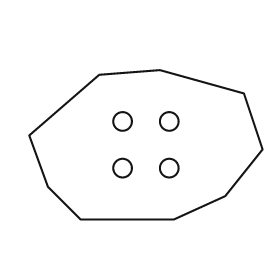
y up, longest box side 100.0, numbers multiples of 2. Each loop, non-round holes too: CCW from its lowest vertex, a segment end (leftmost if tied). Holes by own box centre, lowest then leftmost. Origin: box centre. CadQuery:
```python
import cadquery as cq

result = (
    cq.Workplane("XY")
    .moveTo(-28.0, -32.0)
    .lineTo(12.0, -32.0)
    .lineTo(34.0, -22.0)
    .lineTo(50.0, -2.0)
    .lineTo(42.0, 22.0)
    .lineTo(6.0, 32.0)
    .lineTo(-20.0, 30.0)
    .lineTo(-50.0, 4.0)
    .lineTo(-42.0, -18.0)
    .close()
    .moveTo(-10.0, -10.0)
    .circle(4.0)
    .moveTo(10.0, -10.0)
    .circle(4.0)
    .moveTo(-10.0, 10.0)
    .circle(4.0)
    .moveTo(10.0, 10.0)
    .circle(4.0)
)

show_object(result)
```